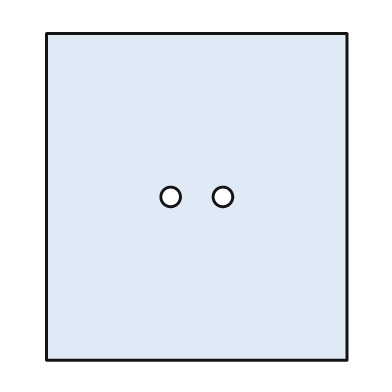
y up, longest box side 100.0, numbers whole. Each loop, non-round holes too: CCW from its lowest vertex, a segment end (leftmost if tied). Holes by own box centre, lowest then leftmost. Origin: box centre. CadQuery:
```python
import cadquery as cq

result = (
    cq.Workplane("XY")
    .moveTo(-46.0, -50.0)
    .lineTo(46.0, -50.0)
    .lineTo(46.0, 50.0)
    .lineTo(-46.0, 50.0)
    .close()
    .moveTo(-8.0, 0.0)
    .circle(3.0)
    .moveTo(8.0, 0.0)
    .circle(3.0)
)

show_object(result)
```